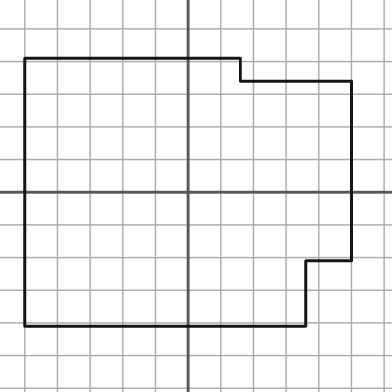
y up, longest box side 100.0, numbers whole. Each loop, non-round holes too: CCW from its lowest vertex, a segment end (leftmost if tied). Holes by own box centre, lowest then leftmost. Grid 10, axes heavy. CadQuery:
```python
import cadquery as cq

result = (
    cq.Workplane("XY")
    .moveTo(-50.0, -41.0)
    .lineTo(36.0, -41.0)
    .lineTo(36.0, -21.0)
    .lineTo(50.0, -21.0)
    .lineTo(50.0, 34.0)
    .lineTo(16.0, 34.0)
    .lineTo(16.0, 41.0)
    .lineTo(-50.0, 41.0)
    .close()
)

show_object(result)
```